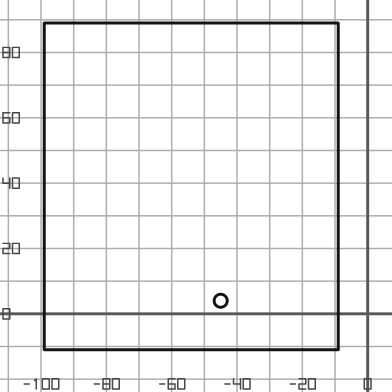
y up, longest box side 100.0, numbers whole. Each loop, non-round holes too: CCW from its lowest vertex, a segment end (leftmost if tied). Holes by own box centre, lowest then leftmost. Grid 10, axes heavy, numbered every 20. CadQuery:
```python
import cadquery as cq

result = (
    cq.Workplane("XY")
    .moveTo(-99.0, -11.0)
    .lineTo(-9.0, -11.0)
    .lineTo(-9.0, 89.0)
    .lineTo(-99.0, 89.0)
    .close()
    .moveTo(-45.0, 4.0)
    .circle(2.0)
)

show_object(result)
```